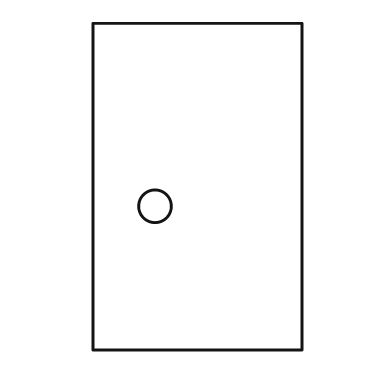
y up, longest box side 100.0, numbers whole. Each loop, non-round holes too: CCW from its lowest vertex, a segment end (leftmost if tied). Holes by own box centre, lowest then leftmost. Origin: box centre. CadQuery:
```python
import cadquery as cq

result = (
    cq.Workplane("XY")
    .moveTo(-32.0, -50.0)
    .lineTo(32.0, -50.0)
    .lineTo(32.0, 50.0)
    .lineTo(-32.0, 50.0)
    .close()
    .moveTo(-13.0, -6.0)
    .circle(5.0)
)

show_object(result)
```